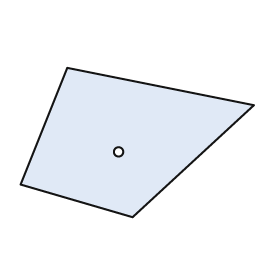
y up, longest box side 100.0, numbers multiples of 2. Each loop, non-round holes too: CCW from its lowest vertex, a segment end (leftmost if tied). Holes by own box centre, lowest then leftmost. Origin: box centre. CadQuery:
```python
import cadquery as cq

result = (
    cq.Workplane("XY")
    .moveTo(-2.0, -32.0)
    .lineTo(50.0, 16.0)
    .lineTo(-30.0, 32.0)
    .lineTo(-50.0, -18.0)
    .close()
    .moveTo(-8.0, -4.0)
    .circle(2.0)
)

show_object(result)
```